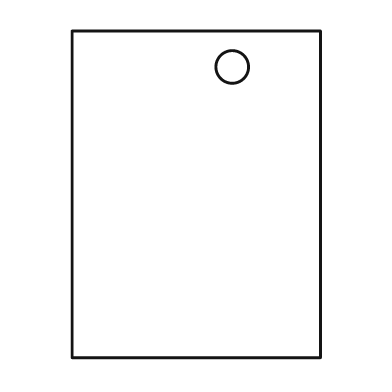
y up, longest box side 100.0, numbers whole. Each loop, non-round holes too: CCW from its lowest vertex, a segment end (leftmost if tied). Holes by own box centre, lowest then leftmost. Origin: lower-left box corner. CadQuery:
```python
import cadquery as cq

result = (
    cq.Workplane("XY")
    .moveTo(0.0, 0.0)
    .lineTo(76.0, 0.0)
    .lineTo(76.0, 100.0)
    .lineTo(0.0, 100.0)
    .close()
    .moveTo(49.0, 89.0)
    .circle(5.0)
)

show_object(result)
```